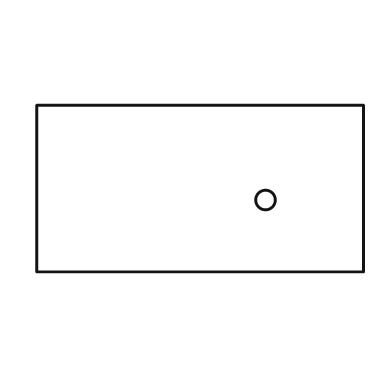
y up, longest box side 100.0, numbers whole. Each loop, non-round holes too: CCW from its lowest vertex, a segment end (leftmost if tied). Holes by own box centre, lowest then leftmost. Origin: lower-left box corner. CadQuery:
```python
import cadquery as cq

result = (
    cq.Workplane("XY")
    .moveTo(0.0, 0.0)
    .lineTo(100.0, 0.0)
    .lineTo(100.0, 51.0)
    .lineTo(0.0, 51.0)
    .close()
    .moveTo(70.0, 22.0)
    .circle(3.0)
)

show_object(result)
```